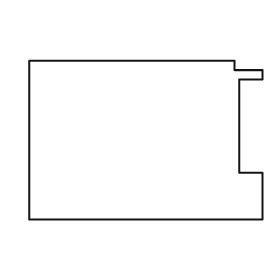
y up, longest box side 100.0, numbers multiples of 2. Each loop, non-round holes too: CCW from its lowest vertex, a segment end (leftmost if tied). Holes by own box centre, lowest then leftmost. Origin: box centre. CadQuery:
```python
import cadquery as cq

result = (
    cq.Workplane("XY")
    .moveTo(-50.0, -34.0)
    .lineTo(50.0, -34.0)
    .lineTo(50.0, -14.0)
    .lineTo(40.0, -14.0)
    .lineTo(40.0, 26.0)
    .lineTo(50.0, 26.0)
    .lineTo(50.0, 30.0)
    .lineTo(38.0, 30.0)
    .lineTo(38.0, 34.0)
    .lineTo(-50.0, 34.0)
    .close()
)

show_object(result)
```